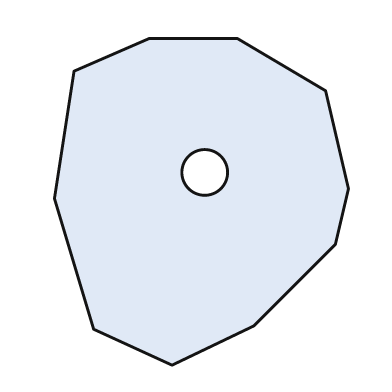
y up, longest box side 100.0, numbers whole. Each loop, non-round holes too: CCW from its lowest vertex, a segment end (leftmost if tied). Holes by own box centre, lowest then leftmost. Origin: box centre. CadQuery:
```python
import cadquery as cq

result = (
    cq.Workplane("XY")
    .moveTo(-9.0, -50.0)
    .lineTo(16.0, -38.0)
    .lineTo(41.0, -13.0)
    .lineTo(45.0, 4.0)
    .lineTo(38.0, 34.0)
    .lineTo(11.0, 50.0)
    .lineTo(-16.0, 50.0)
    .lineTo(-39.0, 40.0)
    .lineTo(-45.0, 1.0)
    .lineTo(-33.0, -39.0)
    .close()
    .moveTo(1.0, 9.0)
    .circle(7.0)
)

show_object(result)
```